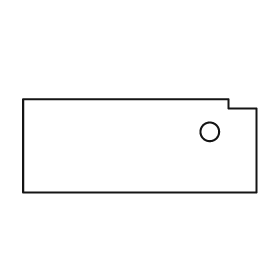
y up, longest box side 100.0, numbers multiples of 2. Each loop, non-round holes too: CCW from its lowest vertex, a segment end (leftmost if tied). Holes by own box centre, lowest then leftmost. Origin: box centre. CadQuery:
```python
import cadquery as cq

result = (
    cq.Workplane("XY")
    .moveTo(-50.0, -20.0)
    .lineTo(50.0, -20.0)
    .lineTo(50.0, 16.0)
    .lineTo(38.0, 16.0)
    .lineTo(38.0, 20.0)
    .lineTo(-50.0, 20.0)
    .close()
    .moveTo(30.0, 6.0)
    .circle(4.0)
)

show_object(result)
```